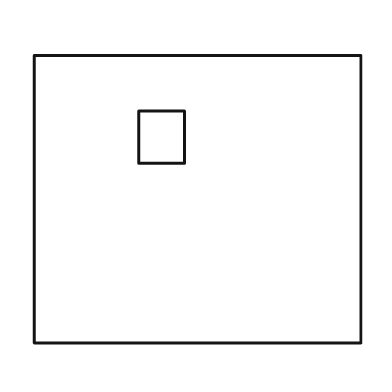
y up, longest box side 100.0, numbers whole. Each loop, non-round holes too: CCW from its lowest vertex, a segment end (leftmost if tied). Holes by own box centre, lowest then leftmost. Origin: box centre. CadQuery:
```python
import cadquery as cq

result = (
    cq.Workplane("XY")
    .moveTo(-50.0, -44.0)
    .lineTo(50.0, -44.0)
    .lineTo(50.0, 44.0)
    .lineTo(-50.0, 44.0)
    .close()
    .moveTo(-18.0, 11.0)
    .lineTo(-4.0, 11.0)
    .lineTo(-4.0, 27.0)
    .lineTo(-18.0, 27.0)
    .close()
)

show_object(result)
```